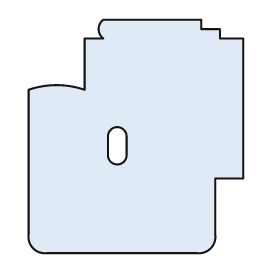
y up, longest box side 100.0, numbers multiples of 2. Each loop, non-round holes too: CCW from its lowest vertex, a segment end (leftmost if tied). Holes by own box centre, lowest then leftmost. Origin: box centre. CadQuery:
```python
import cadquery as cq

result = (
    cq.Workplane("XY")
    .moveTo(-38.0, -50.0)
    .lineTo(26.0, -50.0)
    .threePointArc((32.0, -48.0), (34.0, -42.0))
    .lineTo(34.0, -18.0)
    .lineTo(46.0, -18.0)
    .lineTo(46.0, 42.0)
    .lineTo(36.0, 42.0)
    .lineTo(36.0, 46.0)
    .lineTo(28.0, 46.0)
    .lineTo(28.0, 50.0)
    .lineTo(-14.0, 50.0)
    .threePointArc((-16.0, 46.0), (-14.0, 42.0))
    .lineTo(-22.0, 42.0)
    .lineTo(-22.0, 20.0)
    .threePointArc((-34.0, 22.0), (-46.0, 20.0))
    .lineTo(-46.0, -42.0)
    .threePointArc((-44.0, -48.0), (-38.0, -50.0))
    .close()
    .moveTo(-12.0, -8.0)
    .threePointArc((-8.0, -12.0), (-4.0, -8.0))
    .lineTo(-4.0, 0.0)
    .threePointArc((-8.0, 4.0), (-12.0, 0.0))
    .close()
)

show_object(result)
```